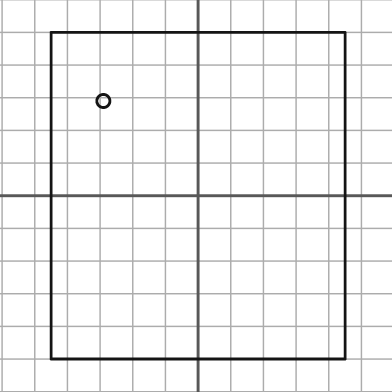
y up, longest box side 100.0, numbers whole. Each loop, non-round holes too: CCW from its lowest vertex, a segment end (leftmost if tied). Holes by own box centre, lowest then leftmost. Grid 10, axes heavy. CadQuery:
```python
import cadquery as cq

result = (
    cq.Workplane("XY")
    .moveTo(-45.0, -50.0)
    .lineTo(45.0, -50.0)
    .lineTo(45.0, 50.0)
    .lineTo(-45.0, 50.0)
    .close()
    .moveTo(-29.0, 29.0)
    .circle(2.0)
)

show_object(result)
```